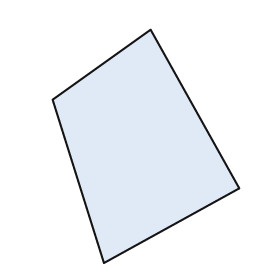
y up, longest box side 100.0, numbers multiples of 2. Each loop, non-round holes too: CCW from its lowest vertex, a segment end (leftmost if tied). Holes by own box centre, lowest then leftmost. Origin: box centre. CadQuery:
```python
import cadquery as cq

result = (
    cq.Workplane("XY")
    .moveTo(-18.0, -50.0)
    .lineTo(40.0, -18.0)
    .lineTo(2.0, 50.0)
    .lineTo(-40.0, 20.0)
    .close()
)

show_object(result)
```